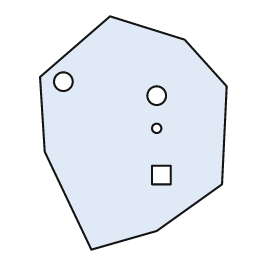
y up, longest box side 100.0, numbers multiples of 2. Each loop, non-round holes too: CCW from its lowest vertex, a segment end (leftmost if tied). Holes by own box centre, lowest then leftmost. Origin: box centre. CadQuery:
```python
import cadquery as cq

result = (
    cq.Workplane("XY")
    .moveTo(-18.0, -50.0)
    .lineTo(10.0, -42.0)
    .lineTo(38.0, -22.0)
    .lineTo(40.0, 20.0)
    .lineTo(22.0, 40.0)
    .lineTo(-10.0, 50.0)
    .lineTo(-40.0, 24.0)
    .lineTo(-38.0, -8.0)
    .close()
    .moveTo(8.0, -22.0)
    .lineTo(16.0, -22.0)
    .lineTo(16.0, -14.0)
    .lineTo(8.0, -14.0)
    .close()
    .moveTo(10.0, 2.0)
    .circle(2.0)
    .moveTo(10.0, 16.0)
    .circle(4.0)
    .moveTo(-30.0, 22.0)
    .circle(4.0)
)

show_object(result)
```